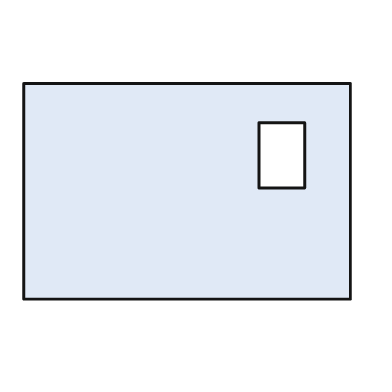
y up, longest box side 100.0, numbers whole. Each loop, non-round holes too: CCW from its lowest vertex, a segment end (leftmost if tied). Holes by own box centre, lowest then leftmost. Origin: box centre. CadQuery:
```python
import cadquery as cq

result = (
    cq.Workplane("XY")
    .moveTo(-50.0, -33.0)
    .lineTo(50.0, -33.0)
    .lineTo(50.0, 33.0)
    .lineTo(-50.0, 33.0)
    .close()
    .moveTo(22.0, 1.0)
    .lineTo(36.0, 1.0)
    .lineTo(36.0, 21.0)
    .lineTo(22.0, 21.0)
    .close()
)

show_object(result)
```